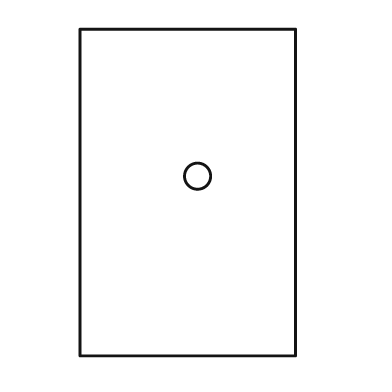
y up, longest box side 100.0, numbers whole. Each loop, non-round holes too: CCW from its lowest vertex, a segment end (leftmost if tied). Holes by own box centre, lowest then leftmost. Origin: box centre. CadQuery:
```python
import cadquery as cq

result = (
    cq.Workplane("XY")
    .moveTo(-33.0, -50.0)
    .lineTo(33.0, -50.0)
    .lineTo(33.0, 50.0)
    .lineTo(-33.0, 50.0)
    .close()
    .moveTo(3.0, 5.0)
    .circle(4.0)
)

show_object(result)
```